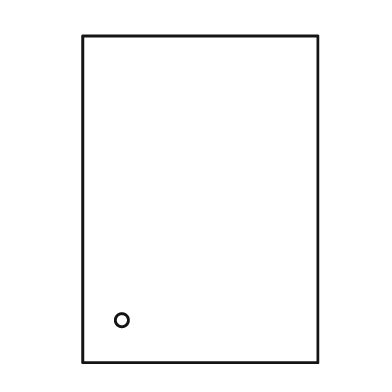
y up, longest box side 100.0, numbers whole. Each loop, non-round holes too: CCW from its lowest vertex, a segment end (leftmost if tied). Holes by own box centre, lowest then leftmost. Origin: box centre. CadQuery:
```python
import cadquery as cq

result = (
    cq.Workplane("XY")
    .moveTo(-36.0, -50.0)
    .lineTo(36.0, -50.0)
    .lineTo(36.0, 50.0)
    .lineTo(-36.0, 50.0)
    .close()
    .moveTo(-24.0, -37.0)
    .circle(2.0)
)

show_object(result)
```